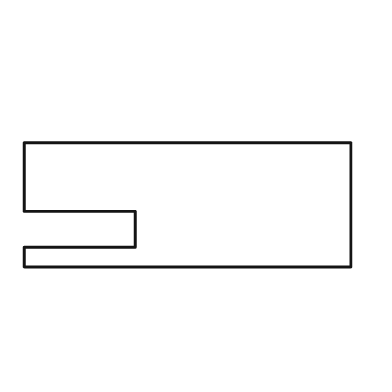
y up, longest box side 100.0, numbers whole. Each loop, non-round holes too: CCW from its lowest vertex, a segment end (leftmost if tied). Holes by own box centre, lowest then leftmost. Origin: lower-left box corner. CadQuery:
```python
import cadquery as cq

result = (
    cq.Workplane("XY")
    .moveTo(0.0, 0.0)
    .lineTo(100.0, 0.0)
    .lineTo(100.0, 38.0)
    .lineTo(0.0, 38.0)
    .lineTo(0.0, 17.0)
    .lineTo(34.0, 17.0)
    .lineTo(34.0, 6.0)
    .lineTo(0.0, 6.0)
    .close()
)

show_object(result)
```